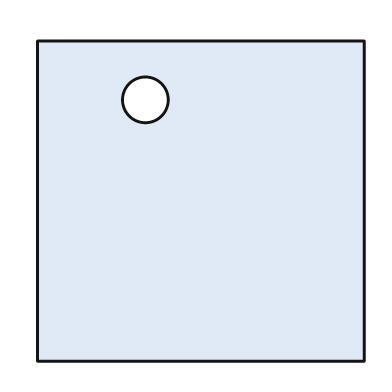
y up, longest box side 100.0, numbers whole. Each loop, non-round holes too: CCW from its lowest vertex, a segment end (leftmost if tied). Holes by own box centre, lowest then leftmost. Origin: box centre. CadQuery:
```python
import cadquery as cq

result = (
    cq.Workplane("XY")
    .moveTo(-50.0, -49.0)
    .lineTo(50.0, -49.0)
    .lineTo(50.0, 49.0)
    .lineTo(-50.0, 49.0)
    .close()
    .moveTo(-17.0, 31.0)
    .circle(7.0)
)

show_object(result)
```